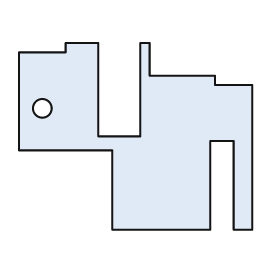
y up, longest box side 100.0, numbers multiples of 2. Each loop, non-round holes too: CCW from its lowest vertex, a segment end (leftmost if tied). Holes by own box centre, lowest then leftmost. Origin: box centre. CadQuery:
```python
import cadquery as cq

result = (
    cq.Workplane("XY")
    .moveTo(-10.0, -40.0)
    .lineTo(32.0, -40.0)
    .lineTo(32.0, -2.0)
    .lineTo(42.0, -2.0)
    .lineTo(42.0, -40.0)
    .lineTo(50.0, -40.0)
    .lineTo(50.0, 22.0)
    .lineTo(34.0, 22.0)
    .lineTo(34.0, 26.0)
    .lineTo(6.0, 26.0)
    .lineTo(6.0, 40.0)
    .lineTo(2.0, 40.0)
    .lineTo(2.0, 0.0)
    .lineTo(-16.0, 0.0)
    .lineTo(-16.0, 40.0)
    .lineTo(-30.0, 40.0)
    .lineTo(-30.0, 36.0)
    .lineTo(-50.0, 36.0)
    .lineTo(-50.0, -6.0)
    .lineTo(-10.0, -6.0)
    .close()
    .moveTo(-40.0, 12.0)
    .circle(4.0)
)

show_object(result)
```